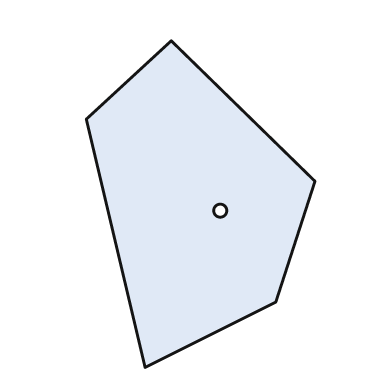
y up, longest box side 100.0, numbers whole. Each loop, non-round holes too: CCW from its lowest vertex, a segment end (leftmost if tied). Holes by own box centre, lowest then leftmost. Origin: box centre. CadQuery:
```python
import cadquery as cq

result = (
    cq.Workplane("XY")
    .moveTo(-17.0, -50.0)
    .lineTo(23.0, -30.0)
    .lineTo(35.0, 7.0)
    .lineTo(-9.0, 50.0)
    .lineTo(-35.0, 26.0)
    .close()
    .moveTo(6.0, -2.0)
    .circle(2.0)
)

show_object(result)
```